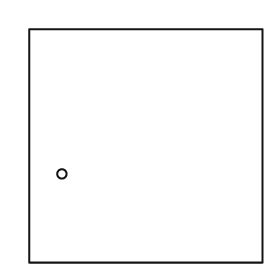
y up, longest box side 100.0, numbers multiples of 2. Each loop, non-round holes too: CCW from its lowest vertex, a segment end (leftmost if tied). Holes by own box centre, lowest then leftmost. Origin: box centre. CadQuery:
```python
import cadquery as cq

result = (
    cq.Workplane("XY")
    .moveTo(-50.0, -50.0)
    .lineTo(50.0, -50.0)
    .lineTo(50.0, 50.0)
    .lineTo(-50.0, 50.0)
    .close()
    .moveTo(-36.0, -12.0)
    .circle(2.0)
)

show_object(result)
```